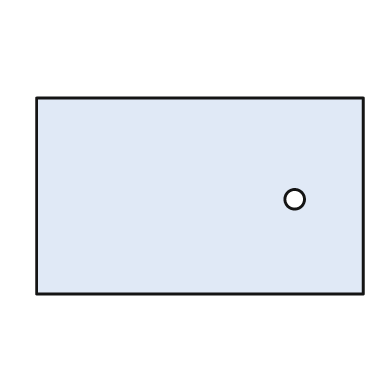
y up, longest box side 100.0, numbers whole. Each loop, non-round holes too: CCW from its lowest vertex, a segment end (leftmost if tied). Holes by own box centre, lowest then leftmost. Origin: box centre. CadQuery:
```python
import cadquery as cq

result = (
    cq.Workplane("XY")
    .moveTo(-50.0, -30.0)
    .lineTo(50.0, -30.0)
    .lineTo(50.0, 30.0)
    .lineTo(-50.0, 30.0)
    .close()
    .moveTo(29.0, -1.0)
    .circle(3.0)
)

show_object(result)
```